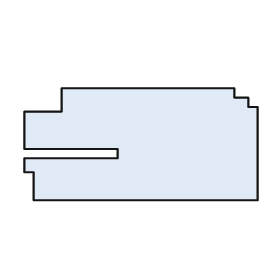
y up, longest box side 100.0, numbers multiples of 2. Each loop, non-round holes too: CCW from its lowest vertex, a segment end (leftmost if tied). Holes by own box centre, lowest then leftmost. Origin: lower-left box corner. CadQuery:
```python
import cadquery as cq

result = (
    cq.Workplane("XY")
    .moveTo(4.0, 0.0)
    .lineTo(100.0, 0.0)
    .lineTo(100.0, 40.0)
    .lineTo(96.0, 40.0)
    .lineTo(96.0, 44.0)
    .lineTo(90.0, 44.0)
    .lineTo(90.0, 48.0)
    .lineTo(16.0, 48.0)
    .lineTo(16.0, 38.0)
    .lineTo(0.0, 38.0)
    .lineTo(0.0, 22.0)
    .lineTo(40.0, 22.0)
    .lineTo(40.0, 18.0)
    .lineTo(0.0, 18.0)
    .lineTo(0.0, 12.0)
    .lineTo(4.0, 12.0)
    .close()
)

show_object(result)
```